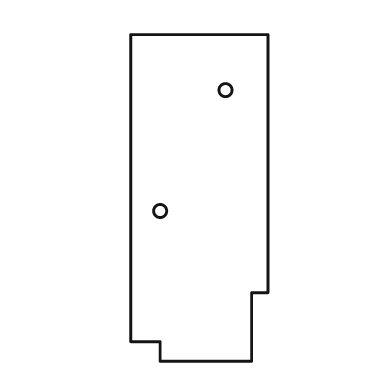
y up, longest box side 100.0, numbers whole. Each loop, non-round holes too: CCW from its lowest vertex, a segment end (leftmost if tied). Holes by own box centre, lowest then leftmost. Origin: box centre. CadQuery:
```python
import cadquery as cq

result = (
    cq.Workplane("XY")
    .moveTo(-12.0, -50.0)
    .lineTo(16.0, -50.0)
    .lineTo(16.0, -29.0)
    .lineTo(21.0, -29.0)
    .lineTo(21.0, 50.0)
    .lineTo(-21.0, 50.0)
    .lineTo(-21.0, -44.0)
    .lineTo(-12.0, -44.0)
    .close()
    .moveTo(-12.0, -4.0)
    .circle(2.0)
    .moveTo(8.0, 33.0)
    .circle(2.0)
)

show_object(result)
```